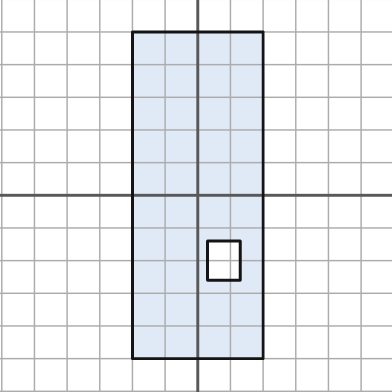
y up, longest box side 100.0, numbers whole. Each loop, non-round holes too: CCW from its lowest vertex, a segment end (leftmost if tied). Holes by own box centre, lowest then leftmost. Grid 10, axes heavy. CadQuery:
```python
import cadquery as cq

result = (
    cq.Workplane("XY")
    .moveTo(-20.0, -50.0)
    .lineTo(20.0, -50.0)
    .lineTo(20.0, 50.0)
    .lineTo(-20.0, 50.0)
    .close()
    .moveTo(3.0, -26.0)
    .lineTo(13.0, -26.0)
    .lineTo(13.0, -14.0)
    .lineTo(3.0, -14.0)
    .close()
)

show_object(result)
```